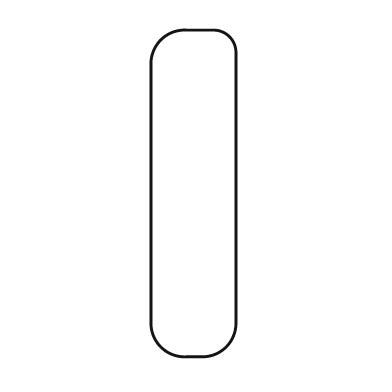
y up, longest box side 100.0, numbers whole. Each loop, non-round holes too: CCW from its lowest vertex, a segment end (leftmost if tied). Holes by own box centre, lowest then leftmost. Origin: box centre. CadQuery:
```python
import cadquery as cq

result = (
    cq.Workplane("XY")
    .moveTo(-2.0, -50.0)
    .lineTo(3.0, -50.0)
    .threePointArc((10.0, -47.0), (13.0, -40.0))
    .lineTo(13.0, 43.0)
    .threePointArc((11.0, 48.0), (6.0, 50.0))
    .lineTo(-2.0, 50.0)
    .threePointArc((-10.0, 47.0), (-13.0, 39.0))
    .lineTo(-13.0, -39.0)
    .threePointArc((-10.0, -47.0), (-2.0, -50.0))
    .close()
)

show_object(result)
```